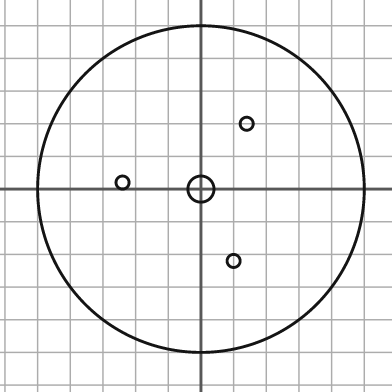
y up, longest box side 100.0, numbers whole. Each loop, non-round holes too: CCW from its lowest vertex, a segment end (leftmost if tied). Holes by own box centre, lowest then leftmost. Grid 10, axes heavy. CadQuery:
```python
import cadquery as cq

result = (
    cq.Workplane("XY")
    .moveTo(0.0, 0.0)
    .circle(50.0)
    .moveTo(10.0, -22.0)
    .circle(2.0)
    .moveTo(0.0, 0.0)
    .circle(4.0)
    .moveTo(-24.0, 2.0)
    .circle(2.0)
    .moveTo(14.0, 20.0)
    .circle(2.0)
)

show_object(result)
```